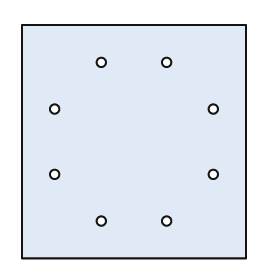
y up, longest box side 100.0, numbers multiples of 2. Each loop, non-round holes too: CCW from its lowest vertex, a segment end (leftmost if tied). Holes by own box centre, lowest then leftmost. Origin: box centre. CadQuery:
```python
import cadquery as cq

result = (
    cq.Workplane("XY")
    .moveTo(-48.0, -50.0)
    .lineTo(48.0, -50.0)
    .lineTo(48.0, 50.0)
    .lineTo(-48.0, 50.0)
    .close()
    .moveTo(-14.0, -34.0)
    .circle(2.0)
    .moveTo(14.0, -34.0)
    .circle(2.0)
    .moveTo(-34.0, -14.0)
    .circle(2.0)
    .moveTo(34.0, -14.0)
    .circle(2.0)
    .moveTo(-34.0, 14.0)
    .circle(2.0)
    .moveTo(34.0, 14.0)
    .circle(2.0)
    .moveTo(-14.0, 34.0)
    .circle(2.0)
    .moveTo(14.0, 34.0)
    .circle(2.0)
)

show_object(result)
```